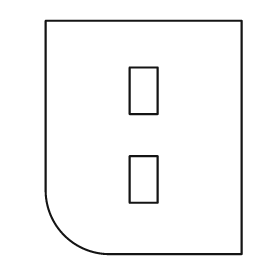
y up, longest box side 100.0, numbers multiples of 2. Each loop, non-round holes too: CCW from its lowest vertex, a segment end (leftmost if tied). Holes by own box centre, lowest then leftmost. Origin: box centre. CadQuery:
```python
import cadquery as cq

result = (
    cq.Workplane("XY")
    .moveTo(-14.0, -50.0)
    .lineTo(42.0, -50.0)
    .lineTo(42.0, 50.0)
    .lineTo(-42.0, 50.0)
    .lineTo(-42.0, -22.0)
    .threePointArc((-34.0, -42.0), (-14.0, -50.0))
    .close()
    .moveTo(-6.0, -28.0)
    .lineTo(6.0, -28.0)
    .lineTo(6.0, -8.0)
    .lineTo(-6.0, -8.0)
    .close()
    .moveTo(-6.0, 10.0)
    .lineTo(6.0, 10.0)
    .lineTo(6.0, 30.0)
    .lineTo(-6.0, 30.0)
    .close()
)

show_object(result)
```